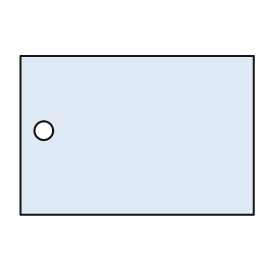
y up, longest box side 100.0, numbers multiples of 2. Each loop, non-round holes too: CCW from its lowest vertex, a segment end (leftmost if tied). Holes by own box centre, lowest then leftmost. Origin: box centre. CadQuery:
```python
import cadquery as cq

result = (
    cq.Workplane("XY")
    .moveTo(-50.0, -34.0)
    .lineTo(50.0, -34.0)
    .lineTo(50.0, 34.0)
    .lineTo(-50.0, 34.0)
    .close()
    .moveTo(-40.0, 2.0)
    .circle(4.0)
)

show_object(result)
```